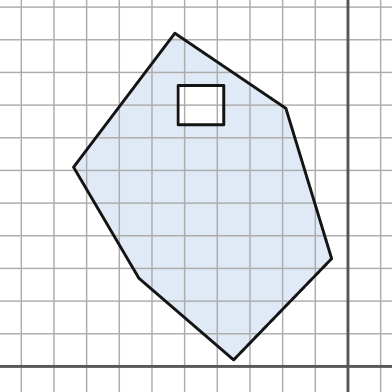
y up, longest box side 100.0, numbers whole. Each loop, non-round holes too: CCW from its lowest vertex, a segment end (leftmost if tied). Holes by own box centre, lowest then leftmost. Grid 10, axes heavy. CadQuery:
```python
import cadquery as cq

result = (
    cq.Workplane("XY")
    .moveTo(-35.0, 2.0)
    .lineTo(-5.0, 33.0)
    .lineTo(-19.0, 79.0)
    .lineTo(-53.0, 102.0)
    .lineTo(-84.0, 61.0)
    .lineTo(-64.0, 27.0)
    .close()
    .moveTo(-52.0, 74.0)
    .lineTo(-38.0, 74.0)
    .lineTo(-38.0, 86.0)
    .lineTo(-52.0, 86.0)
    .close()
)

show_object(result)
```